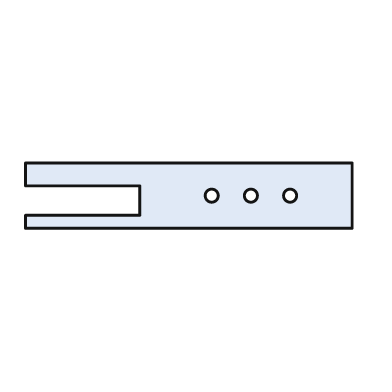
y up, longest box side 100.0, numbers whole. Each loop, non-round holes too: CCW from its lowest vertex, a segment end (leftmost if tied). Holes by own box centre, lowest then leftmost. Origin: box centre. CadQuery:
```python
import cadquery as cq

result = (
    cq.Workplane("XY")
    .moveTo(-50.0, -10.0)
    .lineTo(50.0, -10.0)
    .lineTo(50.0, 10.0)
    .lineTo(-50.0, 10.0)
    .lineTo(-50.0, 3.0)
    .lineTo(-15.0, 3.0)
    .lineTo(-15.0, -6.0)
    .lineTo(-50.0, -6.0)
    .close()
    .moveTo(7.0, 0.0)
    .circle(2.0)
    .moveTo(19.0, 0.0)
    .circle(2.0)
    .moveTo(31.0, 0.0)
    .circle(2.0)
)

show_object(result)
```